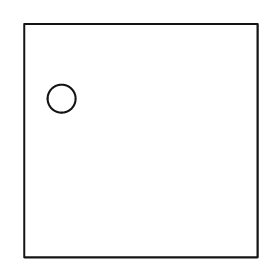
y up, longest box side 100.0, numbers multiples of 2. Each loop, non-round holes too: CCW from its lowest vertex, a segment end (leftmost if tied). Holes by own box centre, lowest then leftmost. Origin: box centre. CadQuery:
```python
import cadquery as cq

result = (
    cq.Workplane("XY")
    .moveTo(-50.0, -50.0)
    .lineTo(50.0, -50.0)
    .lineTo(50.0, 50.0)
    .lineTo(-50.0, 50.0)
    .close()
    .moveTo(-34.0, 18.0)
    .circle(6.0)
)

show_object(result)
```